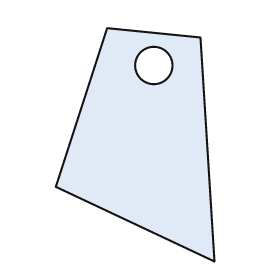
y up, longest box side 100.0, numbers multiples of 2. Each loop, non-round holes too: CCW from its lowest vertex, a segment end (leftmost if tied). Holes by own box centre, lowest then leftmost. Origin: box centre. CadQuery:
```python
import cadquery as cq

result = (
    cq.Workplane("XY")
    .moveTo(34.0, -50.0)
    .lineTo(28.0, 46.0)
    .lineTo(-12.0, 50.0)
    .lineTo(-34.0, -18.0)
    .close()
    .moveTo(8.0, 34.0)
    .circle(8.0)
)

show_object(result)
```